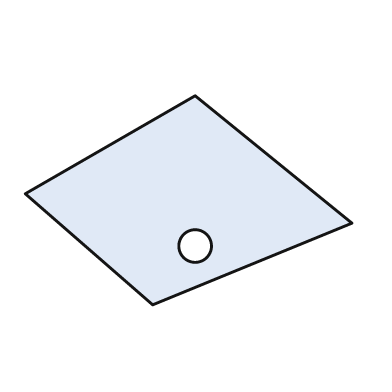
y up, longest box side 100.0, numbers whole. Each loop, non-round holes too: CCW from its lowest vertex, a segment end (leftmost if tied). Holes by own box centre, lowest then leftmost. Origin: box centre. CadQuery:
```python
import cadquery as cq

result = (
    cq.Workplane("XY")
    .moveTo(-11.0, -32.0)
    .lineTo(50.0, -7.0)
    .lineTo(2.0, 32.0)
    .lineTo(-50.0, 2.0)
    .close()
    .moveTo(2.0, -14.0)
    .circle(5.0)
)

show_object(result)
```